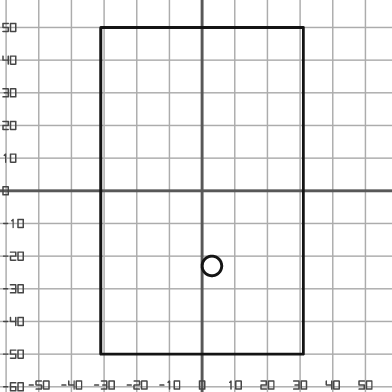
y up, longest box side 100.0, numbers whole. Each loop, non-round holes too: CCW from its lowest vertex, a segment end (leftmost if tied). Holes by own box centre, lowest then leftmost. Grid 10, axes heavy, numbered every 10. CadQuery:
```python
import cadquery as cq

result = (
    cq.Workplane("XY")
    .moveTo(-31.0, -50.0)
    .lineTo(31.0, -50.0)
    .lineTo(31.0, 50.0)
    .lineTo(-31.0, 50.0)
    .close()
    .moveTo(3.0, -23.0)
    .circle(3.0)
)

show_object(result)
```